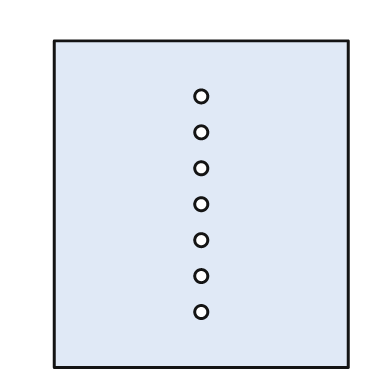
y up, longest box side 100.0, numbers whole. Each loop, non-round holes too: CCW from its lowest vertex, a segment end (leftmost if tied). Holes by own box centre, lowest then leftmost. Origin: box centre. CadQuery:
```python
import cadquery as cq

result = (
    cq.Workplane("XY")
    .moveTo(-45.0, -50.0)
    .lineTo(45.0, -50.0)
    .lineTo(45.0, 50.0)
    .lineTo(-45.0, 50.0)
    .close()
    .moveTo(0.0, -33.0)
    .circle(2.0)
    .moveTo(0.0, -22.0)
    .circle(2.0)
    .moveTo(0.0, -11.0)
    .circle(2.0)
    .moveTo(0.0, 0.0)
    .circle(2.0)
    .moveTo(0.0, 11.0)
    .circle(2.0)
    .moveTo(0.0, 22.0)
    .circle(2.0)
    .moveTo(0.0, 33.0)
    .circle(2.0)
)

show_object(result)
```